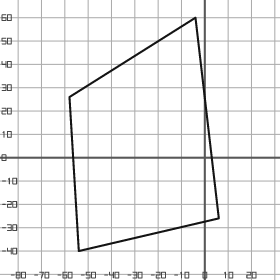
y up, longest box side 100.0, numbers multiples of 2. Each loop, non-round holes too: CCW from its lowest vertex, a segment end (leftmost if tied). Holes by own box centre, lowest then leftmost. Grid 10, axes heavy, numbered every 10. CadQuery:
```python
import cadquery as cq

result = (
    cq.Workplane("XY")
    .moveTo(-54.0, -40.0)
    .lineTo(6.0, -26.0)
    .lineTo(-4.0, 60.0)
    .lineTo(-58.0, 26.0)
    .close()
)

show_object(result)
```